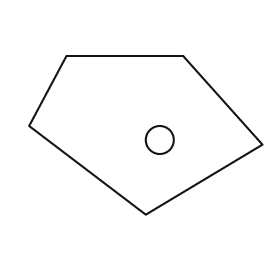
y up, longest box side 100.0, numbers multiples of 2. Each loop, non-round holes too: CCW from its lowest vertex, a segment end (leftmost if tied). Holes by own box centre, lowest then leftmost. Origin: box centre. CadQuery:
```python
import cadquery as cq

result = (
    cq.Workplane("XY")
    .moveTo(0.0, -34.0)
    .lineTo(50.0, -4.0)
    .lineTo(16.0, 34.0)
    .lineTo(-34.0, 34.0)
    .lineTo(-50.0, 4.0)
    .close()
    .moveTo(6.0, -2.0)
    .circle(6.0)
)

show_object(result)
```